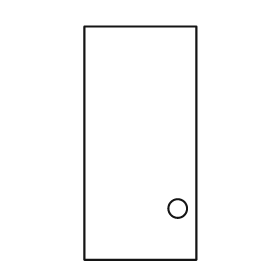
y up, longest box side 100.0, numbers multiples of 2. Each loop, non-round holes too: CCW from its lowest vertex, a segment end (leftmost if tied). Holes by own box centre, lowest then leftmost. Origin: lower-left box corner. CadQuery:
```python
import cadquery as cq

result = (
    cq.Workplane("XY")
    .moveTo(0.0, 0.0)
    .lineTo(48.0, 0.0)
    .lineTo(48.0, 100.0)
    .lineTo(0.0, 100.0)
    .close()
    .moveTo(40.0, 22.0)
    .circle(4.0)
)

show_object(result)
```